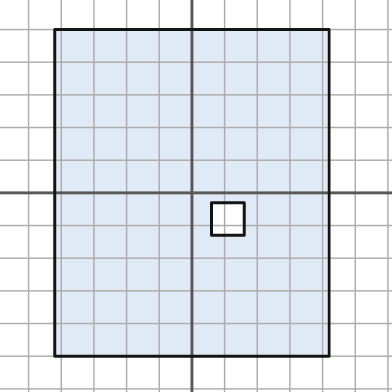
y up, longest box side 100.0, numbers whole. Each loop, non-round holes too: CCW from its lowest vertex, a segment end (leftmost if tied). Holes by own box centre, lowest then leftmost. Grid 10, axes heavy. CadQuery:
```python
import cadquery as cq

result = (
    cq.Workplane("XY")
    .moveTo(-42.0, -50.0)
    .lineTo(42.0, -50.0)
    .lineTo(42.0, 50.0)
    .lineTo(-42.0, 50.0)
    .close()
    .moveTo(6.0, -13.0)
    .lineTo(16.0, -13.0)
    .lineTo(16.0, -3.0)
    .lineTo(6.0, -3.0)
    .close()
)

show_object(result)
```